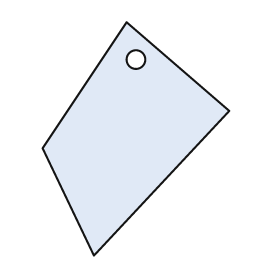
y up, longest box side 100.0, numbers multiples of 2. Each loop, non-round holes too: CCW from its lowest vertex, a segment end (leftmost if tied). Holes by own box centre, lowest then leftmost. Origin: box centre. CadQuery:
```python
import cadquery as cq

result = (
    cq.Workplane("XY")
    .moveTo(-18.0, -50.0)
    .lineTo(40.0, 12.0)
    .lineTo(-4.0, 50.0)
    .lineTo(-40.0, -4.0)
    .close()
    .moveTo(0.0, 34.0)
    .circle(4.0)
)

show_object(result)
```